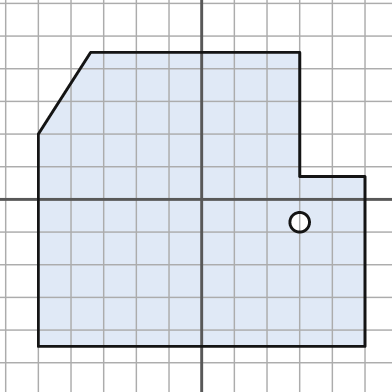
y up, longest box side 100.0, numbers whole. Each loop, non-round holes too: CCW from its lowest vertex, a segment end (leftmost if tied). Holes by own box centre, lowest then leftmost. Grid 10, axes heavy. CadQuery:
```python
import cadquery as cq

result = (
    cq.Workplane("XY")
    .moveTo(-50.0, -45.0)
    .lineTo(50.0, -45.0)
    .lineTo(50.0, 7.0)
    .lineTo(30.0, 7.0)
    .lineTo(30.0, 45.0)
    .lineTo(-34.0, 45.0)
    .lineTo(-50.0, 20.0)
    .close()
    .moveTo(30.0, -7.0)
    .circle(3.0)
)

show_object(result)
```